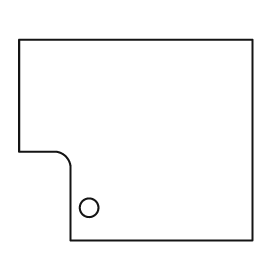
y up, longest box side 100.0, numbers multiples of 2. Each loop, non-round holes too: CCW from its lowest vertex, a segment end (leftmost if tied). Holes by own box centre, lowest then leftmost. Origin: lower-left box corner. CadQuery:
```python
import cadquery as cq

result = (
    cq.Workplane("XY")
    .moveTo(22.0, 0.0)
    .lineTo(100.0, 0.0)
    .lineTo(100.0, 86.0)
    .lineTo(0.0, 86.0)
    .lineTo(0.0, 38.0)
    .lineTo(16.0, 38.0)
    .threePointArc((20.0, 36.0), (22.0, 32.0))
    .close()
    .moveTo(30.0, 14.0)
    .circle(4.0)
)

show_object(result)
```